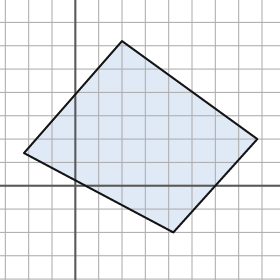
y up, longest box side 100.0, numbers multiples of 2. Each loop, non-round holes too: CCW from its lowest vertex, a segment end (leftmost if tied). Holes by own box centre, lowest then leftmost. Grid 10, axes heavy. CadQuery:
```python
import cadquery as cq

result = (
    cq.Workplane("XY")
    .moveTo(42.0, -20.0)
    .lineTo(78.0, 20.0)
    .lineTo(20.0, 62.0)
    .lineTo(-22.0, 14.0)
    .close()
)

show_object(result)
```